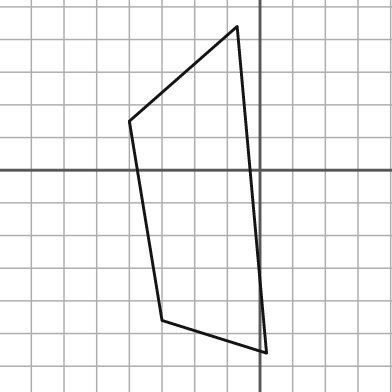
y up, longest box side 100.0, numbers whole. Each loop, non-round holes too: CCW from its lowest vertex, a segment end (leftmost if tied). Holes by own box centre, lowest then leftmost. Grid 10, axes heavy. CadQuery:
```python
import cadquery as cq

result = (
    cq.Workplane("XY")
    .moveTo(2.0, -56.0)
    .lineTo(-7.0, 44.0)
    .lineTo(-40.0, 15.0)
    .lineTo(-30.0, -46.0)
    .close()
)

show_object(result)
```